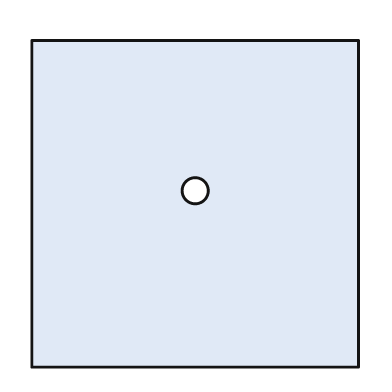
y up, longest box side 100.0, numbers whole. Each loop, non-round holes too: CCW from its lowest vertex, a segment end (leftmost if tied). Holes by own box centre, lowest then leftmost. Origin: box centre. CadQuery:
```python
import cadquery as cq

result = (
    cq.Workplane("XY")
    .moveTo(-50.0, -50.0)
    .lineTo(50.0, -50.0)
    .lineTo(50.0, 50.0)
    .lineTo(-50.0, 50.0)
    .close()
    .moveTo(0.0, 4.0)
    .circle(4.0)
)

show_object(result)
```